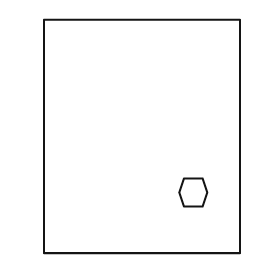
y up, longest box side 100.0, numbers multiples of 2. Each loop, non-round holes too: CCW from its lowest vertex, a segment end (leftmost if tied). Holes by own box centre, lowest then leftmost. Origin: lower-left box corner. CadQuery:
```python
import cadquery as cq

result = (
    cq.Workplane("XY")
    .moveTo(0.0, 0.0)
    .lineTo(84.0, 0.0)
    .lineTo(84.0, 100.0)
    .lineTo(0.0, 100.0)
    .close()
    .moveTo(60.0, 20.0)
    .lineTo(68.0, 20.0)
    .lineTo(70.0, 26.0)
    .lineTo(68.0, 32.0)
    .lineTo(60.0, 32.0)
    .lineTo(58.0, 26.0)
    .close()
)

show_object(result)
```